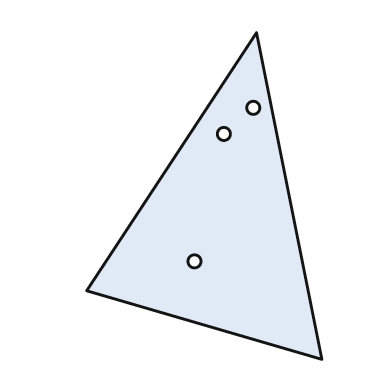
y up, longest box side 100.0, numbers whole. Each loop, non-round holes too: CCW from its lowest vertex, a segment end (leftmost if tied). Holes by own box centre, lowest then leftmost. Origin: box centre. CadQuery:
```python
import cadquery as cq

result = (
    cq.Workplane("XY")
    .moveTo(36.0, -50.0)
    .lineTo(16.0, 50.0)
    .lineTo(-36.0, -29.0)
    .close()
    .moveTo(-3.0, -20.0)
    .circle(2.0)
    .moveTo(6.0, 19.0)
    .circle(2.0)
    .moveTo(15.0, 27.0)
    .circle(2.0)
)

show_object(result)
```